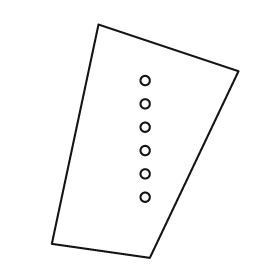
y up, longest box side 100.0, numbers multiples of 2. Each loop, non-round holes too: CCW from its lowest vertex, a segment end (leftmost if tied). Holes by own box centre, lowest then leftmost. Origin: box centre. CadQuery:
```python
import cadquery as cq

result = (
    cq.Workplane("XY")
    .moveTo(2.0, -50.0)
    .lineTo(40.0, 30.0)
    .lineTo(-20.0, 50.0)
    .lineTo(-40.0, -44.0)
    .close()
    .moveTo(0.0, -24.0)
    .circle(2.0)
    .moveTo(0.0, -14.0)
    .circle(2.0)
    .moveTo(0.0, -4.0)
    .circle(2.0)
    .moveTo(0.0, 6.0)
    .circle(2.0)
    .moveTo(0.0, 16.0)
    .circle(2.0)
    .moveTo(0.0, 26.0)
    .circle(2.0)
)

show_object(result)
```